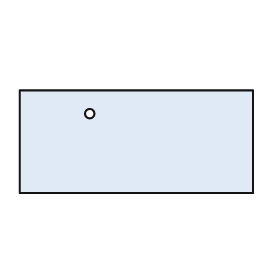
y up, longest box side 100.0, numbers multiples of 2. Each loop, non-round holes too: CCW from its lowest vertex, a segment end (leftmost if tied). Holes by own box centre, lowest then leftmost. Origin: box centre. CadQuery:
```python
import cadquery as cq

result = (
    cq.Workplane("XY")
    .moveTo(-50.0, -22.0)
    .lineTo(50.0, -22.0)
    .lineTo(50.0, 22.0)
    .lineTo(-50.0, 22.0)
    .close()
    .moveTo(-20.0, 12.0)
    .circle(2.0)
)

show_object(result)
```